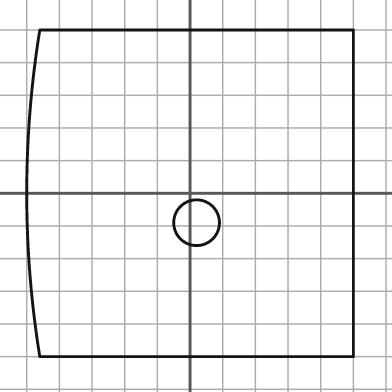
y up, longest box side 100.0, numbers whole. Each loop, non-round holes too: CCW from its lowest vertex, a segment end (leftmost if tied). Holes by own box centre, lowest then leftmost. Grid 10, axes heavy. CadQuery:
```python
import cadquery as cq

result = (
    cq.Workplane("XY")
    .moveTo(-46.0, -50.0)
    .lineTo(50.0, -50.0)
    .lineTo(50.0, 50.0)
    .lineTo(-46.0, 50.0)
    .threePointArc((-50.0, 0.0), (-46.0, -50.0))
    .close()
    .moveTo(2.0, -9.0)
    .circle(7.0)
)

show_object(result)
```